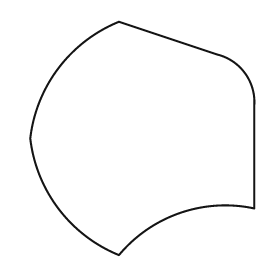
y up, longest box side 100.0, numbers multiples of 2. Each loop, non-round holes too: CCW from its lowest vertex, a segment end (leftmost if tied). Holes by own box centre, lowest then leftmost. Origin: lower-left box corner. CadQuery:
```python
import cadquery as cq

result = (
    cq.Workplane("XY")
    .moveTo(38.0, 0.0)
    .threePointArc((64.0, 18.0), (96.0, 20.0))
    .lineTo(96.0, 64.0)
    .threePointArc((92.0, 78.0), (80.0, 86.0))
    .lineTo(38.0, 100.0)
    .threePointArc((12.0, 80.0), (0.0, 50.0))
    .threePointArc((12.0, 20.0), (38.0, 0.0))
    .close()
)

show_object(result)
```